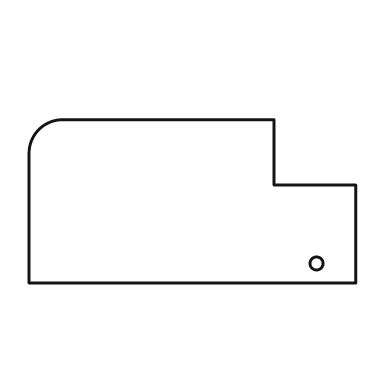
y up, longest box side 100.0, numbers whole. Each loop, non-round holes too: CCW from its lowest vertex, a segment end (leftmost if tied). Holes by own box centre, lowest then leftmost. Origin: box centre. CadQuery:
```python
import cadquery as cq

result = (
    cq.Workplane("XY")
    .moveTo(-50.0, -25.0)
    .lineTo(50.0, -25.0)
    .lineTo(50.0, 5.0)
    .lineTo(25.0, 5.0)
    .lineTo(25.0, 25.0)
    .lineTo(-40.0, 25.0)
    .threePointArc((-47.0, 22.0), (-50.0, 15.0))
    .close()
    .moveTo(38.0, -19.0)
    .circle(2.0)
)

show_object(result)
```